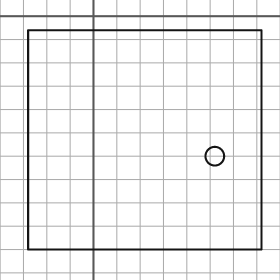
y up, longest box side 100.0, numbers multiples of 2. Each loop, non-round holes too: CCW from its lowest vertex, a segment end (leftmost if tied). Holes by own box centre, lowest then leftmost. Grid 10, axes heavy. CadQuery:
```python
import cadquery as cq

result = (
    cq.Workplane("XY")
    .moveTo(-28.0, -100.0)
    .lineTo(72.0, -100.0)
    .lineTo(72.0, -6.0)
    .lineTo(-28.0, -6.0)
    .close()
    .moveTo(52.0, -60.0)
    .circle(4.0)
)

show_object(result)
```